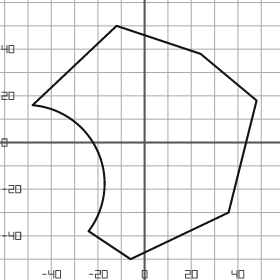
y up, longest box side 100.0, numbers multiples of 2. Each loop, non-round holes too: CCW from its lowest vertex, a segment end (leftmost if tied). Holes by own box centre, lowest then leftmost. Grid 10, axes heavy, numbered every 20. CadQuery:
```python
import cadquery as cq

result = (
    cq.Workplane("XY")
    .moveTo(-6.0, -50.0)
    .lineTo(36.0, -30.0)
    .lineTo(48.0, 18.0)
    .lineTo(24.0, 38.0)
    .lineTo(-12.0, 50.0)
    .lineTo(-48.0, 16.0)
    .threePointArc((-20.0, -4.0), (-24.0, -38.0))
    .close()
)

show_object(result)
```